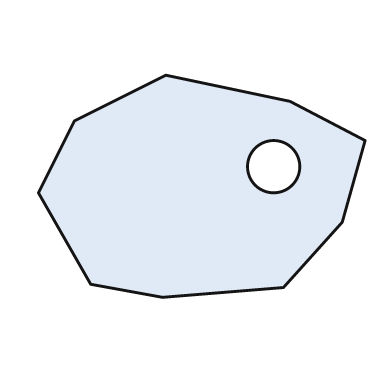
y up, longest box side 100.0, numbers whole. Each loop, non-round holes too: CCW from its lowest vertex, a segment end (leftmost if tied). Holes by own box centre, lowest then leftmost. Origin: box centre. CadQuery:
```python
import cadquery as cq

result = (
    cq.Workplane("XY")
    .moveTo(-12.0, -34.0)
    .lineTo(25.0, -31.0)
    .lineTo(43.0, -11.0)
    .lineTo(50.0, 14.0)
    .lineTo(27.0, 26.0)
    .lineTo(-11.0, 34.0)
    .lineTo(-39.0, 20.0)
    .lineTo(-50.0, -2.0)
    .lineTo(-34.0, -30.0)
    .close()
    .moveTo(22.0, 6.0)
    .circle(8.0)
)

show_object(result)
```